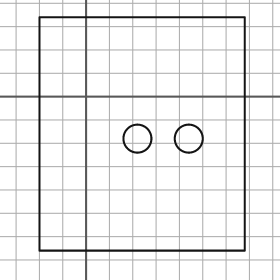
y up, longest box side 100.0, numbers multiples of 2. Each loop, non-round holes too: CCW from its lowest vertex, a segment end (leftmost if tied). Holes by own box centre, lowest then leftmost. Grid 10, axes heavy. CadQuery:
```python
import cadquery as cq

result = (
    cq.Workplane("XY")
    .moveTo(-20.0, -66.0)
    .lineTo(68.0, -66.0)
    .lineTo(68.0, 34.0)
    .lineTo(-20.0, 34.0)
    .close()
    .moveTo(22.0, -18.0)
    .circle(6.0)
    .moveTo(44.0, -18.0)
    .circle(6.0)
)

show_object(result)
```